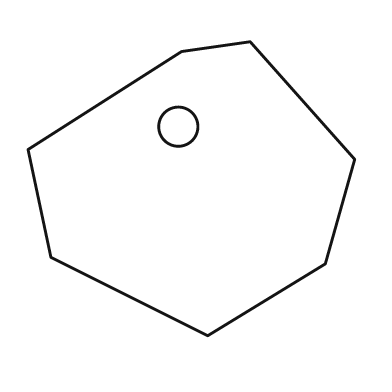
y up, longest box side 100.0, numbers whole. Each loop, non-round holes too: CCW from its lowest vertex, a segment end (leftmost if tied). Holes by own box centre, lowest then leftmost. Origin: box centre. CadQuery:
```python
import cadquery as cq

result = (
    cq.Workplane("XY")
    .moveTo(5.0, -45.0)
    .lineTo(41.0, -23.0)
    .lineTo(50.0, 9.0)
    .lineTo(18.0, 45.0)
    .lineTo(-3.0, 42.0)
    .lineTo(-50.0, 12.0)
    .lineTo(-43.0, -21.0)
    .close()
    .moveTo(-4.0, 19.0)
    .circle(6.0)
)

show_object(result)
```